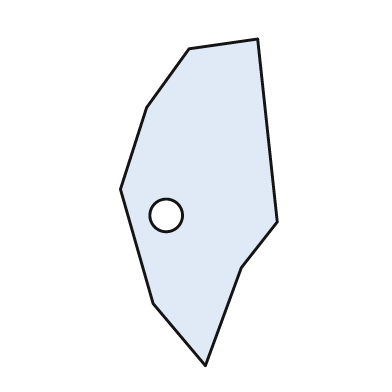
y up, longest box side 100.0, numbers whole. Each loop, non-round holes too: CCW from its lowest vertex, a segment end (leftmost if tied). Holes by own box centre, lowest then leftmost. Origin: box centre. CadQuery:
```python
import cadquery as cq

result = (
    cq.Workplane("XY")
    .moveTo(2.0, -50.0)
    .lineTo(13.0, -20.0)
    .lineTo(24.0, -6.0)
    .lineTo(18.0, 50.0)
    .lineTo(-3.0, 47.0)
    .lineTo(-16.0, 29.0)
    .lineTo(-24.0, 4.0)
    .lineTo(-14.0, -31.0)
    .close()
    .moveTo(-10.0, -4.0)
    .circle(5.0)
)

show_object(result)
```